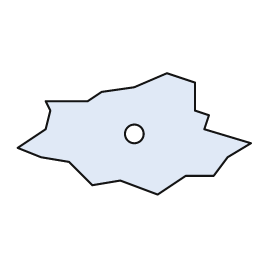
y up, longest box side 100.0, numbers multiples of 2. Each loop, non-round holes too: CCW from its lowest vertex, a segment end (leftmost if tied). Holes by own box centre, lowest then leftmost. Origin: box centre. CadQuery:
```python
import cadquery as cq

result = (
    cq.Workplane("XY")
    .moveTo(10.0, -26.0)
    .lineTo(22.0, -18.0)
    .lineTo(34.0, -18.0)
    .lineTo(40.0, -10.0)
    .lineTo(50.0, -4.0)
    .lineTo(30.0, 2.0)
    .lineTo(32.0, 8.0)
    .lineTo(26.0, 10.0)
    .lineTo(26.0, 22.0)
    .lineTo(14.0, 26.0)
    .lineTo(0.0, 20.0)
    .lineTo(-14.0, 18.0)
    .lineTo(-20.0, 14.0)
    .lineTo(-38.0, 14.0)
    .lineTo(-36.0, 10.0)
    .lineTo(-38.0, 2.0)
    .lineTo(-50.0, -6.0)
    .lineTo(-40.0, -10.0)
    .lineTo(-28.0, -12.0)
    .lineTo(-18.0, -22.0)
    .lineTo(-6.0, -20.0)
    .close()
    .moveTo(0.0, 0.0)
    .circle(4.0)
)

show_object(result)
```